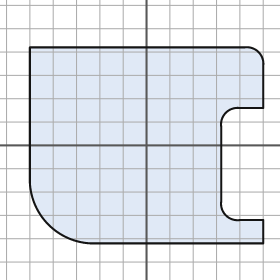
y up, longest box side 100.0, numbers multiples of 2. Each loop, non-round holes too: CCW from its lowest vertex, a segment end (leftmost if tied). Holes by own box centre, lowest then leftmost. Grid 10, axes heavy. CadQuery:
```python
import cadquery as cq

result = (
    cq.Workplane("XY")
    .moveTo(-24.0, -42.0)
    .lineTo(50.0, -42.0)
    .lineTo(50.0, -32.0)
    .lineTo(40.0, -32.0)
    .threePointArc((34.0, -30.0), (32.0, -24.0))
    .lineTo(32.0, 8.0)
    .threePointArc((34.0, 14.0), (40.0, 16.0))
    .lineTo(50.0, 16.0)
    .lineTo(50.0, 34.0)
    .threePointArc((48.0, 40.0), (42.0, 42.0))
    .lineTo(-50.0, 42.0)
    .lineTo(-50.0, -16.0)
    .threePointArc((-42.0, -34.0), (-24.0, -42.0))
    .close()
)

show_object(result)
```